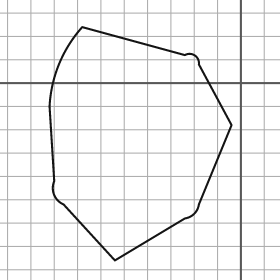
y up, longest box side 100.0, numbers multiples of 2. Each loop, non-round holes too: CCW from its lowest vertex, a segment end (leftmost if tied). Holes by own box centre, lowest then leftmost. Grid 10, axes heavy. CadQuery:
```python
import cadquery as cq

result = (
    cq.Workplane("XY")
    .moveTo(-54.0, -76.0)
    .lineTo(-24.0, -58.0)
    .threePointArc((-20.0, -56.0), (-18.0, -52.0))
    .lineTo(-4.0, -18.0)
    .lineTo(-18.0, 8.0)
    .threePointArc((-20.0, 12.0), (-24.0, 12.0))
    .lineTo(-68.0, 24.0)
    .threePointArc((-78.0, 8.0), (-82.0, -10.0))
    .lineTo(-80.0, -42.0)
    .threePointArc((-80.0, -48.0), (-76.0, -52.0))
    .close()
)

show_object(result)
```